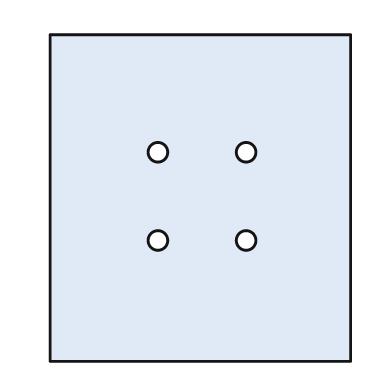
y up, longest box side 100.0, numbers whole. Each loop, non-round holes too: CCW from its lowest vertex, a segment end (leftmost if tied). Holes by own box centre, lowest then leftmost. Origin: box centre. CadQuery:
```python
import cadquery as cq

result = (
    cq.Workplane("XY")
    .moveTo(-46.0, -50.0)
    .lineTo(46.0, -50.0)
    .lineTo(46.0, 50.0)
    .lineTo(-46.0, 50.0)
    .close()
    .moveTo(-13.0, -13.0)
    .circle(3.0)
    .moveTo(14.0, -13.0)
    .circle(3.0)
    .moveTo(-13.0, 14.0)
    .circle(3.0)
    .moveTo(14.0, 14.0)
    .circle(3.0)
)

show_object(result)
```